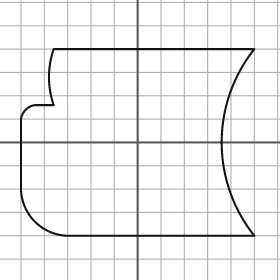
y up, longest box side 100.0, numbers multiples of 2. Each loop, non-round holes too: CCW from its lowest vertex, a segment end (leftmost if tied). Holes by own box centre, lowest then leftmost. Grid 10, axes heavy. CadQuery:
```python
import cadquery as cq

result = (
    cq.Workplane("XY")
    .moveTo(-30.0, -40.0)
    .lineTo(50.0, -40.0)
    .threePointArc((36.0, 0.0), (50.0, 40.0))
    .lineTo(-36.0, 40.0)
    .threePointArc((-38.0, 28.0), (-36.0, 16.0))
    .lineTo(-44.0, 16.0)
    .threePointArc((-48.0, 14.0), (-50.0, 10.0))
    .lineTo(-50.0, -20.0)
    .threePointArc((-44.0, -34.0), (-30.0, -40.0))
    .close()
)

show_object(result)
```